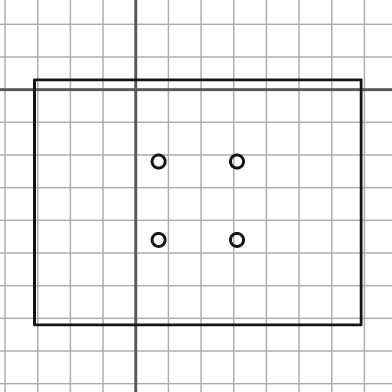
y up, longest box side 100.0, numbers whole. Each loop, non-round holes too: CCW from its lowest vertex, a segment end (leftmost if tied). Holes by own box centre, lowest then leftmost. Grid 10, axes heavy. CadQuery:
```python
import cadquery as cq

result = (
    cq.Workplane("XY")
    .moveTo(-31.0, -72.0)
    .lineTo(69.0, -72.0)
    .lineTo(69.0, 3.0)
    .lineTo(-31.0, 3.0)
    .close()
    .moveTo(7.0, -46.0)
    .circle(2.0)
    .moveTo(31.0, -46.0)
    .circle(2.0)
    .moveTo(7.0, -22.0)
    .circle(2.0)
    .moveTo(31.0, -22.0)
    .circle(2.0)
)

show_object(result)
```